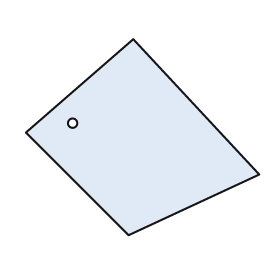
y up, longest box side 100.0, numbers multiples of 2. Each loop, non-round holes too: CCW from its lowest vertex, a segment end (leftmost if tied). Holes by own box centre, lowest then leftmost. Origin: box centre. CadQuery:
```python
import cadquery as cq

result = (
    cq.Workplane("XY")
    .moveTo(-6.0, -42.0)
    .lineTo(50.0, -16.0)
    .lineTo(-4.0, 42.0)
    .lineTo(-50.0, 2.0)
    .close()
    .moveTo(-30.0, 6.0)
    .circle(2.0)
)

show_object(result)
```